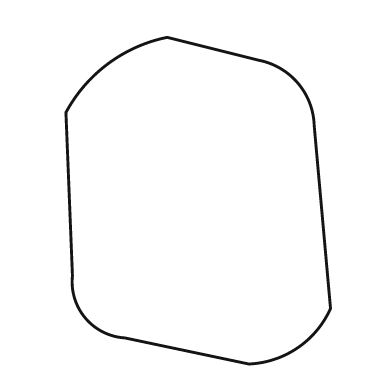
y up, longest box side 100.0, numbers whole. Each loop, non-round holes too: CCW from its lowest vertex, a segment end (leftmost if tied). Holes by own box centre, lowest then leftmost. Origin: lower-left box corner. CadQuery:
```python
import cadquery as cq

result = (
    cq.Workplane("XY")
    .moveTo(56.0, 0.0)
    .threePointArc((71.0, 5.0), (81.0, 17.0))
    .lineTo(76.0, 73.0)
    .threePointArc((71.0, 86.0), (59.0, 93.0))
    .lineTo(31.0, 100.0)
    .threePointArc((13.0, 92.0), (0.0, 77.0))
    .lineTo(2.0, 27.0)
    .threePointArc((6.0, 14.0), (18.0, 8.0))
    .close()
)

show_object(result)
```